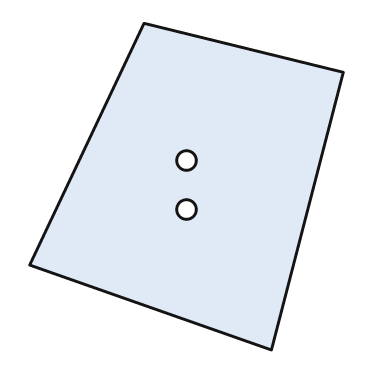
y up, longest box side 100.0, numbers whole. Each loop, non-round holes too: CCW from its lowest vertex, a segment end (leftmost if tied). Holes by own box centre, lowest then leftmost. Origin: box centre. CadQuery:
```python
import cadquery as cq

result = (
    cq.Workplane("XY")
    .moveTo(26.0, -50.0)
    .lineTo(48.0, 35.0)
    .lineTo(-13.0, 50.0)
    .lineTo(-48.0, -24.0)
    .close()
    .moveTo(0.0, -7.0)
    .circle(3.0)
    .moveTo(0.0, 8.0)
    .circle(3.0)
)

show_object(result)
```